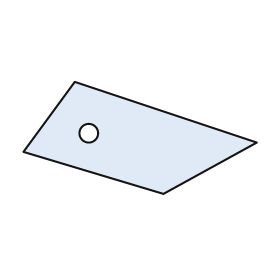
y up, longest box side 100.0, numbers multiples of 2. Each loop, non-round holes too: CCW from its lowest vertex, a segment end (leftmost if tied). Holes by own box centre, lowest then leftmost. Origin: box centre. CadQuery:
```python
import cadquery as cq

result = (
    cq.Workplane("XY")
    .moveTo(10.0, -24.0)
    .lineTo(50.0, -2.0)
    .lineTo(-28.0, 24.0)
    .lineTo(-50.0, -6.0)
    .close()
    .moveTo(-22.0, 2.0)
    .circle(4.0)
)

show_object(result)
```